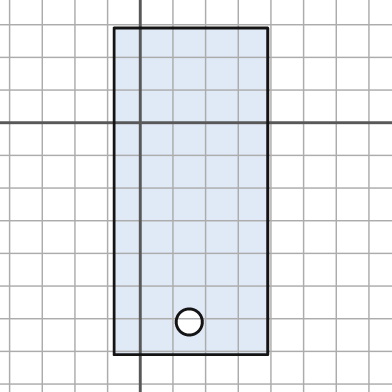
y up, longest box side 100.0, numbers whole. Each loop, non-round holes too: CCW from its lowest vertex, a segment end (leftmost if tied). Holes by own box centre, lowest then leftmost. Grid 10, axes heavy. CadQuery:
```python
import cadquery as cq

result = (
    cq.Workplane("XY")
    .moveTo(-8.0, -71.0)
    .lineTo(39.0, -71.0)
    .lineTo(39.0, 29.0)
    .lineTo(-8.0, 29.0)
    .close()
    .moveTo(15.0, -61.0)
    .circle(4.0)
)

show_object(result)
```